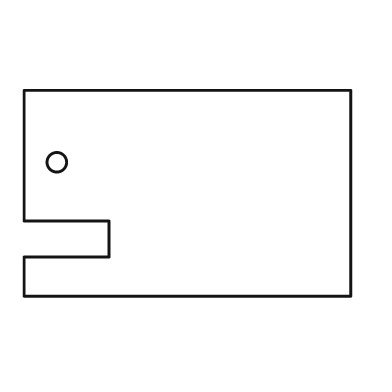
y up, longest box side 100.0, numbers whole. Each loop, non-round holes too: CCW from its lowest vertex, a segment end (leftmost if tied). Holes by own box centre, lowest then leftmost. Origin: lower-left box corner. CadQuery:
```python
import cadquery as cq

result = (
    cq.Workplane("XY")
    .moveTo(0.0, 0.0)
    .lineTo(100.0, 0.0)
    .lineTo(100.0, 63.0)
    .lineTo(0.0, 63.0)
    .lineTo(0.0, 23.0)
    .lineTo(26.0, 23.0)
    .lineTo(26.0, 12.0)
    .lineTo(0.0, 12.0)
    .close()
    .moveTo(10.0, 41.0)
    .circle(3.0)
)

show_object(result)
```